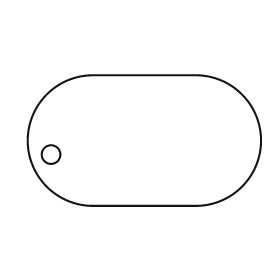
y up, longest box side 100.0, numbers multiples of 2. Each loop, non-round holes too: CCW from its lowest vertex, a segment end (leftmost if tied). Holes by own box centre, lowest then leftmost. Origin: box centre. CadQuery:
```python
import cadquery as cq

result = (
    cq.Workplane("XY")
    .moveTo(-22.0, -28.0)
    .lineTo(22.0, -28.0)
    .threePointArc((50.0, 0.0), (22.0, 28.0))
    .lineTo(-22.0, 28.0)
    .threePointArc((-50.0, 0.0), (-22.0, -28.0))
    .close()
    .moveTo(-40.0, -6.0)
    .circle(4.0)
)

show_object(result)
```